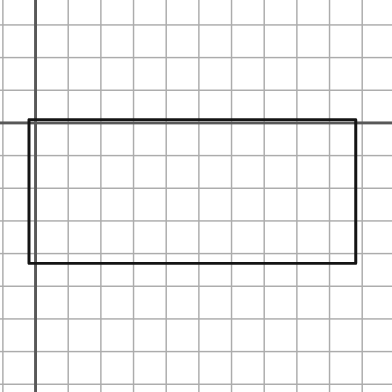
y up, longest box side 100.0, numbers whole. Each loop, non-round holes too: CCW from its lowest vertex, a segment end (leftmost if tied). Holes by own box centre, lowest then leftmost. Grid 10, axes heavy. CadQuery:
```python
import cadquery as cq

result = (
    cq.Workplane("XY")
    .moveTo(-2.0, -43.0)
    .lineTo(98.0, -43.0)
    .lineTo(98.0, 1.0)
    .lineTo(-2.0, 1.0)
    .close()
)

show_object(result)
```